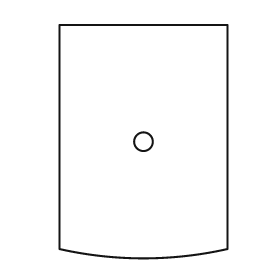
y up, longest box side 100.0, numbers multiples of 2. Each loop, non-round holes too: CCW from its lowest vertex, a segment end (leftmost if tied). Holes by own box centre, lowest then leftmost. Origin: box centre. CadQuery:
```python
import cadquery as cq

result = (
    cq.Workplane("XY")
    .moveTo(-36.0, -46.0)
    .threePointArc((0.0, -50.0), (36.0, -46.0))
    .lineTo(36.0, 50.0)
    .lineTo(-36.0, 50.0)
    .close()
    .moveTo(0.0, 0.0)
    .circle(4.0)
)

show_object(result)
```